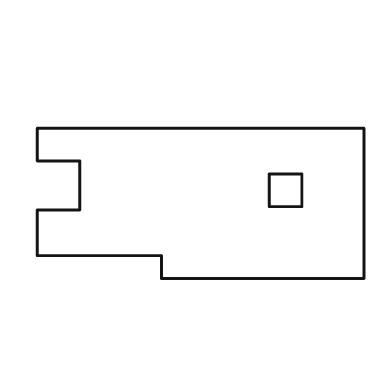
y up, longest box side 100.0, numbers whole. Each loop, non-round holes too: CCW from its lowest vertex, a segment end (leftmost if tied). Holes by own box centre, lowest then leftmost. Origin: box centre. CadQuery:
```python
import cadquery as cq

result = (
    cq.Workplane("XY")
    .moveTo(-12.0, -23.0)
    .lineTo(50.0, -23.0)
    .lineTo(50.0, 23.0)
    .lineTo(-50.0, 23.0)
    .lineTo(-50.0, 13.0)
    .lineTo(-37.0, 13.0)
    .lineTo(-37.0, -2.0)
    .lineTo(-50.0, -2.0)
    .lineTo(-50.0, -16.0)
    .lineTo(-12.0, -16.0)
    .close()
    .moveTo(21.0, -1.0)
    .lineTo(31.0, -1.0)
    .lineTo(31.0, 9.0)
    .lineTo(21.0, 9.0)
    .close()
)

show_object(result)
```